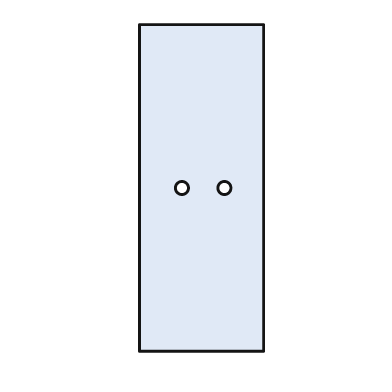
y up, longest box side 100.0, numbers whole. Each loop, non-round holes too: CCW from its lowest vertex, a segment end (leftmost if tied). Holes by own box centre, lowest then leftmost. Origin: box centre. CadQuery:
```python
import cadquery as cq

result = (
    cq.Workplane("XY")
    .moveTo(-19.0, -50.0)
    .lineTo(19.0, -50.0)
    .lineTo(19.0, 50.0)
    .lineTo(-19.0, 50.0)
    .close()
    .moveTo(-6.0, 0.0)
    .circle(2.0)
    .moveTo(7.0, 0.0)
    .circle(2.0)
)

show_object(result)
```